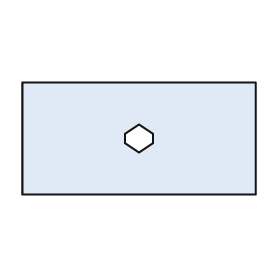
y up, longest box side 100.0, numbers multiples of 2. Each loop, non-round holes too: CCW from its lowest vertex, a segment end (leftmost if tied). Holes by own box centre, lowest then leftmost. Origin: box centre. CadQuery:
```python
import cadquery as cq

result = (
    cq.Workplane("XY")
    .moveTo(-50.0, -24.0)
    .lineTo(50.0, -24.0)
    .lineTo(50.0, 24.0)
    .lineTo(-50.0, 24.0)
    .close()
    .moveTo(0.0, -6.0)
    .lineTo(6.0, -2.0)
    .lineTo(6.0, 2.0)
    .lineTo(0.0, 6.0)
    .lineTo(-6.0, 2.0)
    .lineTo(-6.0, -2.0)
    .close()
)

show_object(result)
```